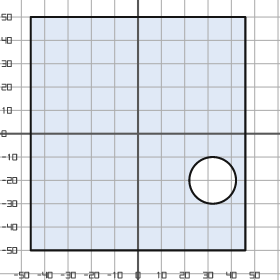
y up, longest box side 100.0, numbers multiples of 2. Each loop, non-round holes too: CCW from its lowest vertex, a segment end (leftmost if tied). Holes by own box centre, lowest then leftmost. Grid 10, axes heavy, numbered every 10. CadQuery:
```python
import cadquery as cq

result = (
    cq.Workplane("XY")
    .moveTo(-46.0, -50.0)
    .lineTo(46.0, -50.0)
    .lineTo(46.0, 50.0)
    .lineTo(-46.0, 50.0)
    .close()
    .moveTo(32.0, -20.0)
    .circle(10.0)
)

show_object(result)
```